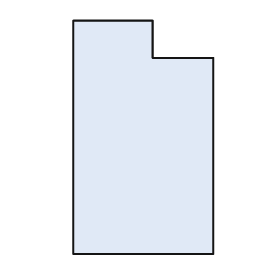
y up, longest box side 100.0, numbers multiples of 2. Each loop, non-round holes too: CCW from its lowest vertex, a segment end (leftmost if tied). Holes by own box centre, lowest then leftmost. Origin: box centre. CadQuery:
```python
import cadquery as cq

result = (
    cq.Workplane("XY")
    .moveTo(-30.0, -50.0)
    .lineTo(30.0, -50.0)
    .lineTo(30.0, 34.0)
    .lineTo(4.0, 34.0)
    .lineTo(4.0, 50.0)
    .lineTo(-30.0, 50.0)
    .close()
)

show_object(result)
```